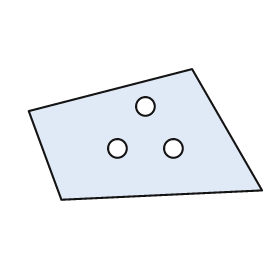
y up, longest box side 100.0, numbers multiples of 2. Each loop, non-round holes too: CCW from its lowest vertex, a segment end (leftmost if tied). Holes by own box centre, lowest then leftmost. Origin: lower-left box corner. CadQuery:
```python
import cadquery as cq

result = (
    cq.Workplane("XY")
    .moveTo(14.0, 0.0)
    .lineTo(100.0, 4.0)
    .lineTo(70.0, 56.0)
    .lineTo(0.0, 38.0)
    .close()
    .moveTo(38.0, 22.0)
    .circle(4.0)
    .moveTo(62.0, 22.0)
    .circle(4.0)
    .moveTo(50.0, 40.0)
    .circle(4.0)
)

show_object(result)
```